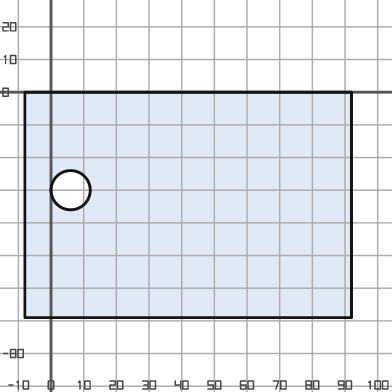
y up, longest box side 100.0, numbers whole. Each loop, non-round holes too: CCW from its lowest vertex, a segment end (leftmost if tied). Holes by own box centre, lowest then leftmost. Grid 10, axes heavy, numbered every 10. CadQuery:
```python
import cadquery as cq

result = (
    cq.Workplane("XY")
    .moveTo(-8.0, -69.0)
    .lineTo(92.0, -69.0)
    .lineTo(92.0, 0.0)
    .lineTo(-8.0, 0.0)
    .close()
    .moveTo(6.0, -30.0)
    .circle(6.0)
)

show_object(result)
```